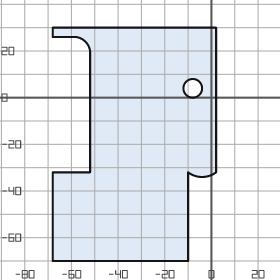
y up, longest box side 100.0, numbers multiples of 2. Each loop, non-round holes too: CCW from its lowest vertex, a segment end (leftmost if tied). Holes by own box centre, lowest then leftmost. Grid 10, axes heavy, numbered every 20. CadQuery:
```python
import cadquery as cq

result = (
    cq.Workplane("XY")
    .moveTo(-68.0, -70.0)
    .lineTo(-10.0, -70.0)
    .lineTo(-10.0, -32.0)
    .threePointArc((-4.0, -34.0), (2.0, -32.0))
    .lineTo(2.0, 30.0)
    .lineTo(-68.0, 30.0)
    .lineTo(-68.0, 26.0)
    .lineTo(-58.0, 26.0)
    .threePointArc((-54.0, 24.0), (-52.0, 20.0))
    .lineTo(-52.0, -32.0)
    .lineTo(-68.0, -32.0)
    .close()
    .moveTo(-8.0, 4.0)
    .circle(4.0)
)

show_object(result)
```